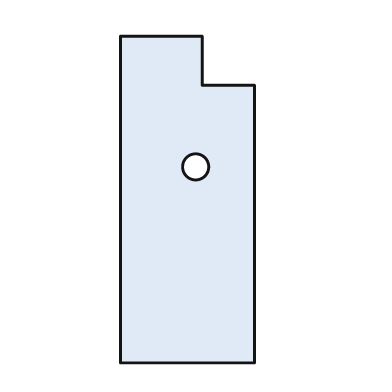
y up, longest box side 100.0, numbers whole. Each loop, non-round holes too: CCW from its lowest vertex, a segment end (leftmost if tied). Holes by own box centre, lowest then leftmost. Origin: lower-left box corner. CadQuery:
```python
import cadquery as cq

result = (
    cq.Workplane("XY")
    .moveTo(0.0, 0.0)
    .lineTo(41.0, 0.0)
    .lineTo(41.0, 85.0)
    .lineTo(25.0, 85.0)
    .lineTo(25.0, 100.0)
    .lineTo(0.0, 100.0)
    .close()
    .moveTo(23.0, 60.0)
    .circle(4.0)
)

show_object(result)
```